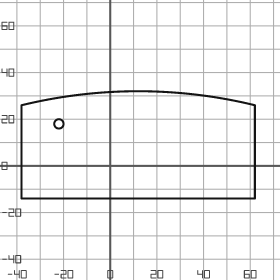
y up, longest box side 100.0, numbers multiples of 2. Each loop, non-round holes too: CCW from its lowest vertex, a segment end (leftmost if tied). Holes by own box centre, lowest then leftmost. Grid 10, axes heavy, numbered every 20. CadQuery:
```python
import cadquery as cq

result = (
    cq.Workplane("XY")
    .moveTo(-38.0, -14.0)
    .lineTo(62.0, -14.0)
    .lineTo(62.0, 26.0)
    .threePointArc((12.0, 32.0), (-38.0, 26.0))
    .close()
    .moveTo(-22.0, 18.0)
    .circle(2.0)
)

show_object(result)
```